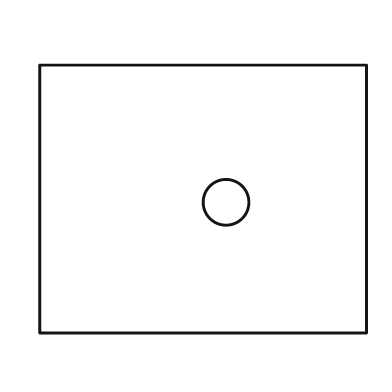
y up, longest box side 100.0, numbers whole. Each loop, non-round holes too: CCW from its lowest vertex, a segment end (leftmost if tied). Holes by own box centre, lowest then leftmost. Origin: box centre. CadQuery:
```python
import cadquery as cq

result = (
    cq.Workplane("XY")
    .moveTo(-50.0, -41.0)
    .lineTo(50.0, -41.0)
    .lineTo(50.0, 41.0)
    .lineTo(-50.0, 41.0)
    .close()
    .moveTo(7.0, -1.0)
    .circle(7.0)
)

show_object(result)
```